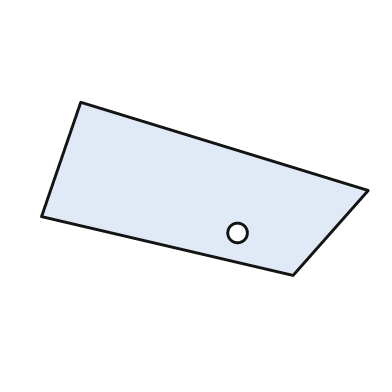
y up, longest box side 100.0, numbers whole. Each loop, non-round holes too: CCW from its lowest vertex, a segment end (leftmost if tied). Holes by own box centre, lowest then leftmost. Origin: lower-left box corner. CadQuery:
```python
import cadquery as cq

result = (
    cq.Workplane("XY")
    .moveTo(77.0, 0.0)
    .lineTo(100.0, 26.0)
    .lineTo(12.0, 53.0)
    .lineTo(0.0, 18.0)
    .close()
    .moveTo(60.0, 13.0)
    .circle(3.0)
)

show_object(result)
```